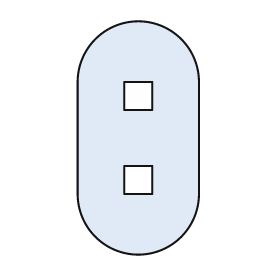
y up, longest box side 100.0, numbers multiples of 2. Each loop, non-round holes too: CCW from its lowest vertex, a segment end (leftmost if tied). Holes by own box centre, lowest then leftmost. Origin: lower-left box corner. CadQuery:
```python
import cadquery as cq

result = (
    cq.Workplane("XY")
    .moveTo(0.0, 26.0)
    .threePointArc((26.0, 0.0), (52.0, 26.0))
    .lineTo(52.0, 74.0)
    .threePointArc((26.0, 100.0), (0.0, 74.0))
    .close()
    .moveTo(20.0, 26.0)
    .lineTo(32.0, 26.0)
    .lineTo(32.0, 38.0)
    .lineTo(20.0, 38.0)
    .close()
    .moveTo(20.0, 62.0)
    .lineTo(32.0, 62.0)
    .lineTo(32.0, 74.0)
    .lineTo(20.0, 74.0)
    .close()
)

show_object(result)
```